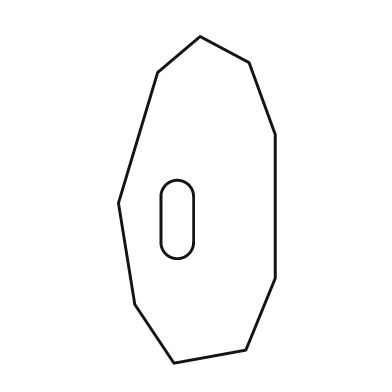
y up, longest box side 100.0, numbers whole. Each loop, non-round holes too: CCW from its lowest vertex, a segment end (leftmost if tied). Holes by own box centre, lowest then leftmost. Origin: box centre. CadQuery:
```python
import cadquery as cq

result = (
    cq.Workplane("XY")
    .moveTo(-7.0, -50.0)
    .lineTo(15.0, -46.0)
    .lineTo(24.0, -24.0)
    .lineTo(24.0, 20.0)
    .lineTo(16.0, 42.0)
    .lineTo(1.0, 50.0)
    .lineTo(-12.0, 39.0)
    .lineTo(-24.0, -1.0)
    .lineTo(-19.0, -32.0)
    .close()
    .moveTo(-11.0, -13.0)
    .threePointArc((-6.0, -18.0), (-1.0, -13.0))
    .lineTo(-1.0, 1.0)
    .threePointArc((-6.0, 6.0), (-11.0, 1.0))
    .close()
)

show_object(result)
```